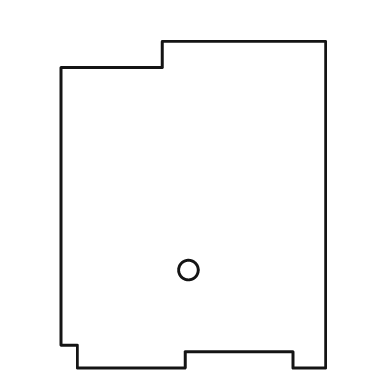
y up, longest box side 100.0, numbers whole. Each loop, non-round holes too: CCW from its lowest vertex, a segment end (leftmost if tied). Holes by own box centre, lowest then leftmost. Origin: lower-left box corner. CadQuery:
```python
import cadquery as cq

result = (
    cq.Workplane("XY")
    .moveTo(5.0, 0.0)
    .lineTo(38.0, 0.0)
    .lineTo(38.0, 5.0)
    .lineTo(71.0, 5.0)
    .lineTo(71.0, 0.0)
    .lineTo(81.0, 0.0)
    .lineTo(81.0, 100.0)
    .lineTo(31.0, 100.0)
    .lineTo(31.0, 92.0)
    .lineTo(0.0, 92.0)
    .lineTo(0.0, 7.0)
    .lineTo(5.0, 7.0)
    .close()
    .moveTo(39.0, 30.0)
    .circle(3.0)
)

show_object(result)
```